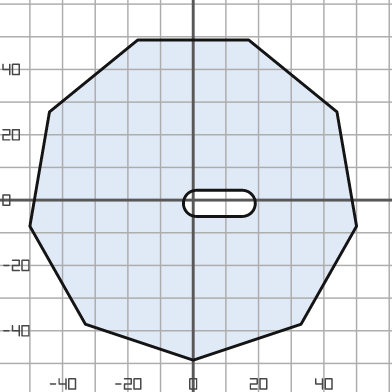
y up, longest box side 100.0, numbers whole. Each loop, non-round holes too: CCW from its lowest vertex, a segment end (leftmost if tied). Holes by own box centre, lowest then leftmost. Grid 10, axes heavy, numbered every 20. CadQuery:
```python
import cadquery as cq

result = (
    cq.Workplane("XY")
    .moveTo(0.0, -49.0)
    .lineTo(33.0, -38.0)
    .lineTo(50.0, -8.0)
    .lineTo(44.0, 27.0)
    .lineTo(17.0, 49.0)
    .lineTo(-17.0, 49.0)
    .lineTo(-44.0, 27.0)
    .lineTo(-50.0, -8.0)
    .lineTo(-33.0, -38.0)
    .close()
    .moveTo(1.0, -5.0)
    .lineTo(15.0, -5.0)
    .threePointArc((19.0, -1.0), (15.0, 3.0))
    .lineTo(1.0, 3.0)
    .threePointArc((-3.0, -1.0), (1.0, -5.0))
    .close()
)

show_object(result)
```